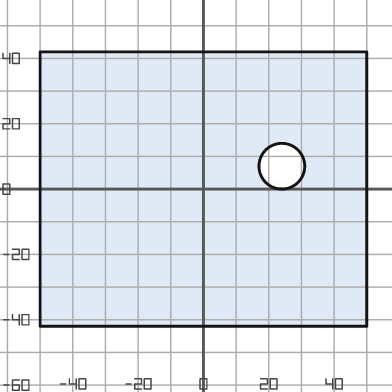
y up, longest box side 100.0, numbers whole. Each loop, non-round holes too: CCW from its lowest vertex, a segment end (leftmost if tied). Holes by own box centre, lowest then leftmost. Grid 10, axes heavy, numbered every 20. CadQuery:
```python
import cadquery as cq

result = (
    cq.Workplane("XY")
    .moveTo(-50.0, -42.0)
    .lineTo(50.0, -42.0)
    .lineTo(50.0, 42.0)
    .lineTo(-50.0, 42.0)
    .close()
    .moveTo(24.0, 7.0)
    .circle(7.0)
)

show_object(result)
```